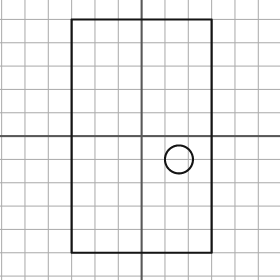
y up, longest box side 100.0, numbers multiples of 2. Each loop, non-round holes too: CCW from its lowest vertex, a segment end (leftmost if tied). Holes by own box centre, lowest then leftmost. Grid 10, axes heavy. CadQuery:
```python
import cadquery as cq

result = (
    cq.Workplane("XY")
    .moveTo(-30.0, -50.0)
    .lineTo(30.0, -50.0)
    .lineTo(30.0, 50.0)
    .lineTo(-30.0, 50.0)
    .close()
    .moveTo(16.0, -10.0)
    .circle(6.0)
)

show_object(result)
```